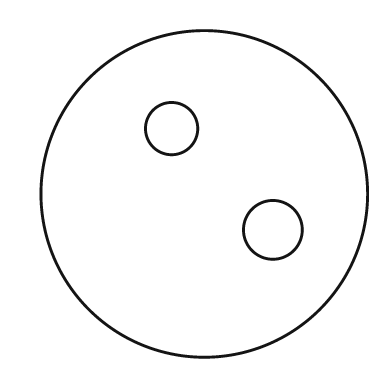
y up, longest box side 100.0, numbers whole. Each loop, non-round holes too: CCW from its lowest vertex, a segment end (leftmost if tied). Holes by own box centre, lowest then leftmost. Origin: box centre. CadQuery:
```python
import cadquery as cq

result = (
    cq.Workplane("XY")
    .moveTo(0.0, 0.0)
    .circle(50.0)
    .moveTo(21.0, -11.0)
    .circle(9.0)
    .moveTo(-10.0, 20.0)
    .circle(8.0)
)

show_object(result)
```